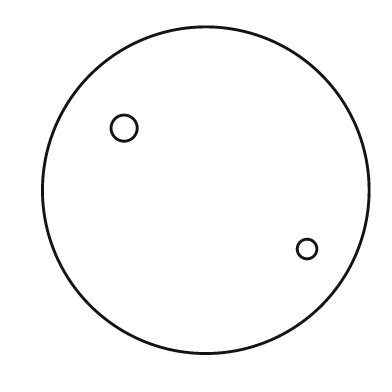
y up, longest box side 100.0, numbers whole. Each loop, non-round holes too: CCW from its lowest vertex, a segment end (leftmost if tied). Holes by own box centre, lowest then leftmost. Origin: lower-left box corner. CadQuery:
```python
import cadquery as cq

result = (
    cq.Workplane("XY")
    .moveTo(50.0, 50.0)
    .circle(50.0)
    .moveTo(81.0, 32.0)
    .circle(3.0)
    .moveTo(25.0, 69.0)
    .circle(4.0)
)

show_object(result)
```